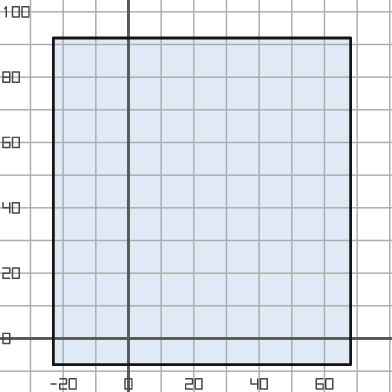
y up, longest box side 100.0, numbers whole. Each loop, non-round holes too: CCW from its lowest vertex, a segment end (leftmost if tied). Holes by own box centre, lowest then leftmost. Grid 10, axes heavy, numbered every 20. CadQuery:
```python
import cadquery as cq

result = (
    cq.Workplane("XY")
    .moveTo(-23.0, -8.0)
    .lineTo(68.0, -8.0)
    .lineTo(68.0, 92.0)
    .lineTo(-23.0, 92.0)
    .close()
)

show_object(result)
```